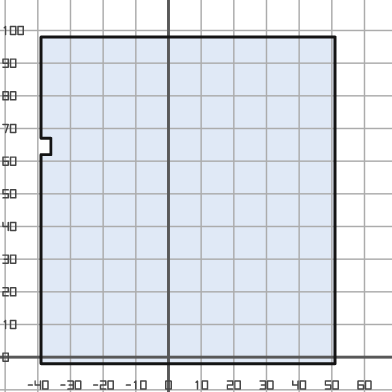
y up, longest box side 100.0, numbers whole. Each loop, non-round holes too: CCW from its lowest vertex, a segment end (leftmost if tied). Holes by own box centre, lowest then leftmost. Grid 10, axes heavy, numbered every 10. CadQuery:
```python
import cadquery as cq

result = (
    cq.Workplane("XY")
    .moveTo(-39.0, -2.0)
    .lineTo(51.0, -2.0)
    .lineTo(51.0, 98.0)
    .lineTo(-39.0, 98.0)
    .lineTo(-39.0, 67.0)
    .lineTo(-36.0, 67.0)
    .lineTo(-36.0, 62.0)
    .lineTo(-39.0, 62.0)
    .close()
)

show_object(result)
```